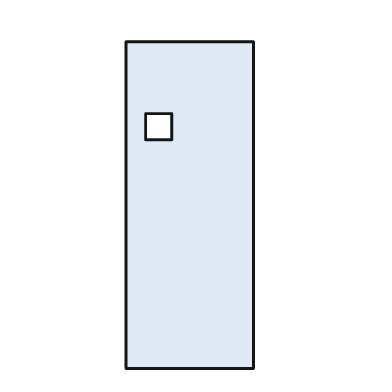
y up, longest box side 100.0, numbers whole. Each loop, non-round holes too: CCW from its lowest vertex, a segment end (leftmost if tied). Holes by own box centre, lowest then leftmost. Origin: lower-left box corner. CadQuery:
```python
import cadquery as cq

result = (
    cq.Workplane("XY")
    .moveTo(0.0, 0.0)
    .lineTo(39.0, 0.0)
    .lineTo(39.0, 100.0)
    .lineTo(0.0, 100.0)
    .close()
    .moveTo(6.0, 70.0)
    .lineTo(14.0, 70.0)
    .lineTo(14.0, 78.0)
    .lineTo(6.0, 78.0)
    .close()
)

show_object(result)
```